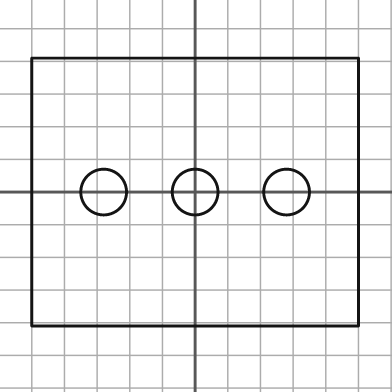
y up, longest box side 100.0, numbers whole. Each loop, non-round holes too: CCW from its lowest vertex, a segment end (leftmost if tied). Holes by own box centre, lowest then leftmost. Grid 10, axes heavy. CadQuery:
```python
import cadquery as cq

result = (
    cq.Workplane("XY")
    .moveTo(-50.0, -41.0)
    .lineTo(50.0, -41.0)
    .lineTo(50.0, 41.0)
    .lineTo(-50.0, 41.0)
    .close()
    .moveTo(-28.0, 0.0)
    .circle(7.0)
    .moveTo(0.0, 0.0)
    .circle(7.0)
    .moveTo(28.0, 0.0)
    .circle(7.0)
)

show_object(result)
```